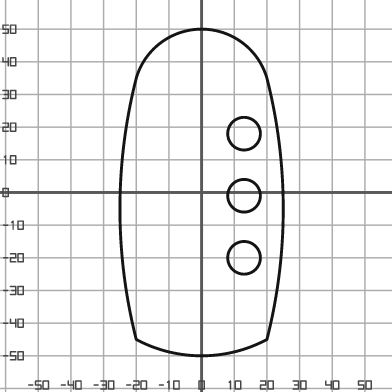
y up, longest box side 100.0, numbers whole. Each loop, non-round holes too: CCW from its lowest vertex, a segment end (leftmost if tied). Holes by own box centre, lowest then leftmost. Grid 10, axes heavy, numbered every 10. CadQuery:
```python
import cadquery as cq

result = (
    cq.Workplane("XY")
    .moveTo(-20.0, -45.0)
    .threePointArc((0.0, -50.0), (20.0, -45.0))
    .threePointArc((25.0, -5.0), (20.0, 35.0))
    .threePointArc((0.0, 50.0), (-20.0, 35.0))
    .threePointArc((-25.0, -5.0), (-20.0, -45.0))
    .close()
    .moveTo(13.0, -20.0)
    .circle(5.0)
    .moveTo(13.0, -1.0)
    .circle(5.0)
    .moveTo(13.0, 18.0)
    .circle(5.0)
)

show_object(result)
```